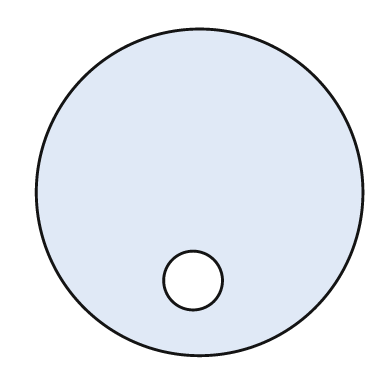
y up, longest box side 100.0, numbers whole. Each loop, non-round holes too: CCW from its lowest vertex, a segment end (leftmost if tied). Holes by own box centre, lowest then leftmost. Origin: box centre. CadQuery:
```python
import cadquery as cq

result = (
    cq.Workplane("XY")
    .moveTo(0.0, 0.0)
    .circle(50.0)
    .moveTo(-2.0, -27.0)
    .circle(9.0)
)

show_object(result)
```